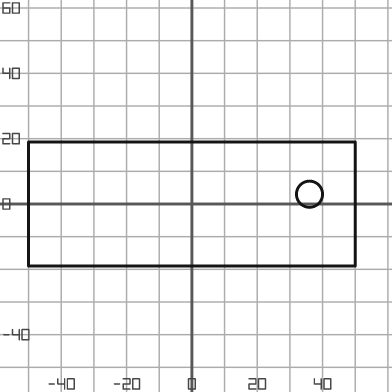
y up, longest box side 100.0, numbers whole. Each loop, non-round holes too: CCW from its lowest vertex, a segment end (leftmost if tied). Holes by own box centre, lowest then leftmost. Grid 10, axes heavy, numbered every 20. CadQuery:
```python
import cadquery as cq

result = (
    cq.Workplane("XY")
    .moveTo(-50.0, -19.0)
    .lineTo(50.0, -19.0)
    .lineTo(50.0, 19.0)
    .lineTo(-50.0, 19.0)
    .close()
    .moveTo(36.0, 3.0)
    .circle(4.0)
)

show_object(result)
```